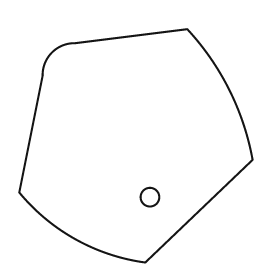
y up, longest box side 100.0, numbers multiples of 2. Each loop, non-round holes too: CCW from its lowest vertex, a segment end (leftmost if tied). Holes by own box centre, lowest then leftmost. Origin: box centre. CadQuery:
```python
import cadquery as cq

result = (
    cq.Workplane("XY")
    .moveTo(4.0, -50.0)
    .lineTo(50.0, -6.0)
    .threePointArc((40.0, 24.0), (22.0, 50.0))
    .lineTo(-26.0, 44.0)
    .threePointArc((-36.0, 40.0), (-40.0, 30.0))
    .lineTo(-50.0, -20.0)
    .threePointArc((-26.0, -40.0), (4.0, -50.0))
    .close()
    .moveTo(6.0, -22.0)
    .circle(4.0)
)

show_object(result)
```